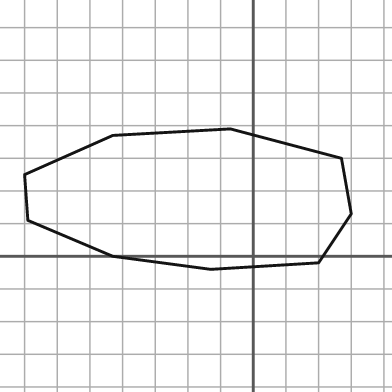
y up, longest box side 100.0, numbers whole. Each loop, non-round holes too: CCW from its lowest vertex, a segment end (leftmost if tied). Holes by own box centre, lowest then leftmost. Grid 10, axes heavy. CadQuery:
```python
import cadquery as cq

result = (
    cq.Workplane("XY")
    .moveTo(-13.0, -4.0)
    .lineTo(20.0, -2.0)
    .lineTo(30.0, 13.0)
    .lineTo(27.0, 30.0)
    .lineTo(-7.0, 39.0)
    .lineTo(-43.0, 37.0)
    .lineTo(-70.0, 25.0)
    .lineTo(-69.0, 11.0)
    .lineTo(-43.0, 0.0)
    .close()
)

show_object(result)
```